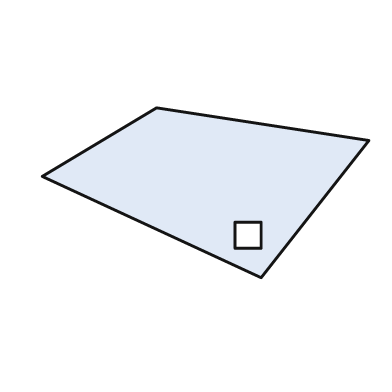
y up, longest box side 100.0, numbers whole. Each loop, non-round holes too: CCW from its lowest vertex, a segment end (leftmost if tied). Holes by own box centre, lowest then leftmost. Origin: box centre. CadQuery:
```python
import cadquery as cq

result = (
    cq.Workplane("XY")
    .moveTo(17.0, -26.0)
    .lineTo(50.0, 16.0)
    .lineTo(-15.0, 26.0)
    .lineTo(-50.0, 5.0)
    .close()
    .moveTo(9.0, -17.0)
    .lineTo(17.0, -17.0)
    .lineTo(17.0, -9.0)
    .lineTo(9.0, -9.0)
    .close()
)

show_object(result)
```